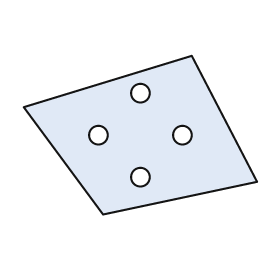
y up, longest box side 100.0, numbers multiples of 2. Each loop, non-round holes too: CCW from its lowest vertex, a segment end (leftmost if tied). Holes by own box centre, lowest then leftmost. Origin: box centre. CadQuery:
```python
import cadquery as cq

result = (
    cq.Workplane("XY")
    .moveTo(-16.0, -34.0)
    .lineTo(50.0, -20.0)
    .lineTo(22.0, 34.0)
    .lineTo(-50.0, 12.0)
    .close()
    .moveTo(0.0, -18.0)
    .circle(4.0)
    .moveTo(-18.0, 0.0)
    .circle(4.0)
    .moveTo(18.0, 0.0)
    .circle(4.0)
    .moveTo(0.0, 18.0)
    .circle(4.0)
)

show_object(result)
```